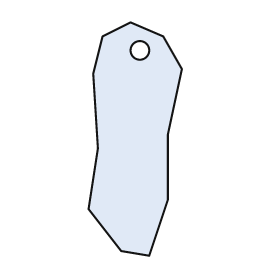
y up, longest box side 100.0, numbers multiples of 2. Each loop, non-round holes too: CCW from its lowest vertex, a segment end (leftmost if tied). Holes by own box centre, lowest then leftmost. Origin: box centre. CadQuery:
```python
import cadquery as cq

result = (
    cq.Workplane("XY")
    .moveTo(6.0, -50.0)
    .lineTo(14.0, -26.0)
    .lineTo(14.0, 2.0)
    .lineTo(20.0, 30.0)
    .lineTo(12.0, 44.0)
    .lineTo(-2.0, 50.0)
    .lineTo(-14.0, 44.0)
    .lineTo(-18.0, 28.0)
    .lineTo(-16.0, -4.0)
    .lineTo(-20.0, -30.0)
    .lineTo(-6.0, -48.0)
    .close()
    .moveTo(2.0, 38.0)
    .circle(4.0)
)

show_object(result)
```